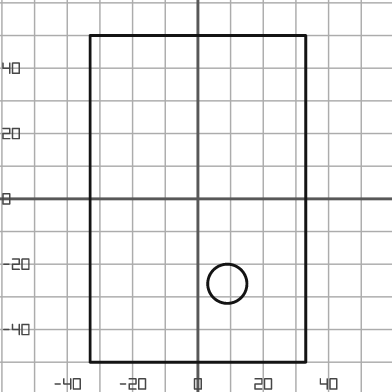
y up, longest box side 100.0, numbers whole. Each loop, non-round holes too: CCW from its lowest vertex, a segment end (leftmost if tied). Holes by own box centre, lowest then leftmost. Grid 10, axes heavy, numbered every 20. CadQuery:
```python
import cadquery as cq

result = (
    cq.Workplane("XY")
    .moveTo(-33.0, -50.0)
    .lineTo(33.0, -50.0)
    .lineTo(33.0, 50.0)
    .lineTo(-33.0, 50.0)
    .close()
    .moveTo(9.0, -26.0)
    .circle(6.0)
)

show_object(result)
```